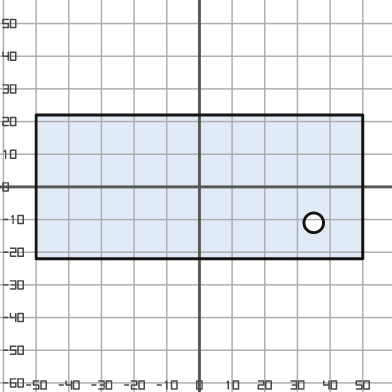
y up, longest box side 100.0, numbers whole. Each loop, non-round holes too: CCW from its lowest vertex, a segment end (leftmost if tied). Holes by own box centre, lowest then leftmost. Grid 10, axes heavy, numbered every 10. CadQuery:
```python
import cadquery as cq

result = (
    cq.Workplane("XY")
    .moveTo(-50.0, -22.0)
    .lineTo(50.0, -22.0)
    .lineTo(50.0, 22.0)
    .lineTo(-50.0, 22.0)
    .close()
    .moveTo(35.0, -11.0)
    .circle(3.0)
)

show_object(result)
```